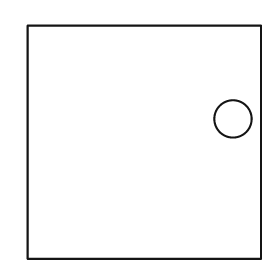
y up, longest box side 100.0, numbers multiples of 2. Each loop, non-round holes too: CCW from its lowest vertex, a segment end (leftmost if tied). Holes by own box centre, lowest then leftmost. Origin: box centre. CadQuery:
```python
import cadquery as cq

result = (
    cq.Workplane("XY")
    .moveTo(-50.0, -50.0)
    .lineTo(50.0, -50.0)
    .lineTo(50.0, 50.0)
    .lineTo(-50.0, 50.0)
    .close()
    .moveTo(38.0, 10.0)
    .circle(8.0)
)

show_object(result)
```